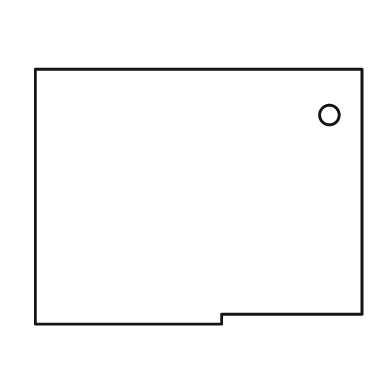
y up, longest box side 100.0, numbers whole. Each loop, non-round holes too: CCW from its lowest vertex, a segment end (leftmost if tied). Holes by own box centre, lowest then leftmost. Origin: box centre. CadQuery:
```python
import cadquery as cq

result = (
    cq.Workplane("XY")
    .moveTo(-50.0, -39.0)
    .lineTo(7.0, -39.0)
    .lineTo(7.0, -36.0)
    .lineTo(50.0, -36.0)
    .lineTo(50.0, 39.0)
    .lineTo(-50.0, 39.0)
    .close()
    .moveTo(40.0, 25.0)
    .circle(3.0)
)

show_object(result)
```